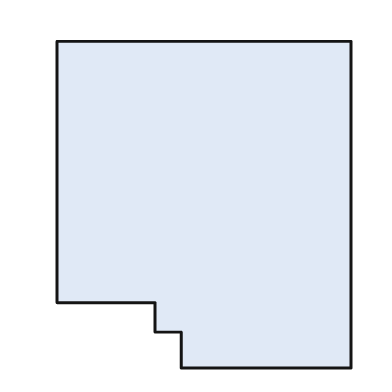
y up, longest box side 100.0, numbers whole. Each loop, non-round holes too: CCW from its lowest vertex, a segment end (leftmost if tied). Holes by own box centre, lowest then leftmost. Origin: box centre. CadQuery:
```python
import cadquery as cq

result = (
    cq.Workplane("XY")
    .moveTo(-7.0, -50.0)
    .lineTo(45.0, -50.0)
    .lineTo(45.0, 50.0)
    .lineTo(-45.0, 50.0)
    .lineTo(-45.0, -30.0)
    .lineTo(-15.0, -30.0)
    .lineTo(-15.0, -39.0)
    .lineTo(-7.0, -39.0)
    .close()
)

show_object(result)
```